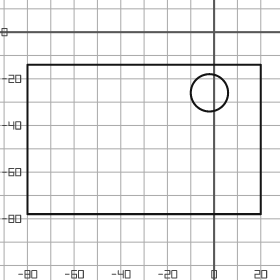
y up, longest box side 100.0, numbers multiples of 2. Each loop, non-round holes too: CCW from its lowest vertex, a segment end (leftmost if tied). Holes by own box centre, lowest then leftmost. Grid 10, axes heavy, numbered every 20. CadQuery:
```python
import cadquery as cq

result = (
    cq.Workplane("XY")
    .moveTo(-80.0, -78.0)
    .lineTo(20.0, -78.0)
    .lineTo(20.0, -14.0)
    .lineTo(-80.0, -14.0)
    .close()
    .moveTo(-2.0, -26.0)
    .circle(8.0)
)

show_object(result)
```